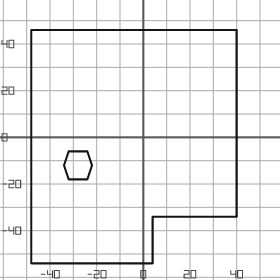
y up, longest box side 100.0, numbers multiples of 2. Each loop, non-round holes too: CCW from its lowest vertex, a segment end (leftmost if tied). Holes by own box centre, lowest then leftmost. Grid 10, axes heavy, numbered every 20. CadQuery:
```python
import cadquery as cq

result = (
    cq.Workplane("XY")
    .moveTo(-48.0, -54.0)
    .lineTo(4.0, -54.0)
    .lineTo(4.0, -34.0)
    .lineTo(40.0, -34.0)
    .lineTo(40.0, 46.0)
    .lineTo(-48.0, 46.0)
    .close()
    .moveTo(-32.0, -18.0)
    .lineTo(-24.0, -18.0)
    .lineTo(-22.0, -12.0)
    .lineTo(-24.0, -6.0)
    .lineTo(-32.0, -6.0)
    .lineTo(-34.0, -12.0)
    .close()
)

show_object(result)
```